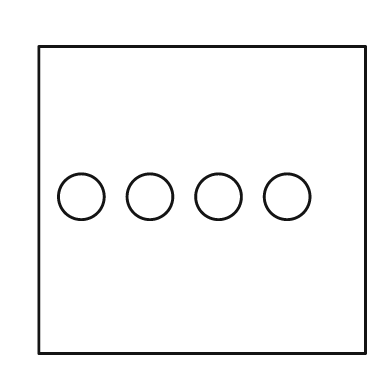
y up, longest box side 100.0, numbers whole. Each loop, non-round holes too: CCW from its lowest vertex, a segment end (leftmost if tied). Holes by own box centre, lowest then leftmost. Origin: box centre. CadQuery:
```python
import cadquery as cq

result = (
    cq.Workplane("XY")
    .moveTo(-50.0, -47.0)
    .lineTo(50.0, -47.0)
    .lineTo(50.0, 47.0)
    .lineTo(-50.0, 47.0)
    .close()
    .moveTo(-37.0, 1.0)
    .circle(7.0)
    .moveTo(-16.0, 1.0)
    .circle(7.0)
    .moveTo(5.0, 1.0)
    .circle(7.0)
    .moveTo(26.0, 1.0)
    .circle(7.0)
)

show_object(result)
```